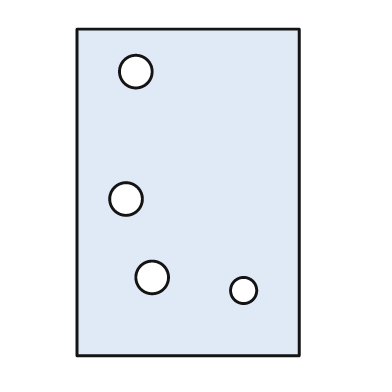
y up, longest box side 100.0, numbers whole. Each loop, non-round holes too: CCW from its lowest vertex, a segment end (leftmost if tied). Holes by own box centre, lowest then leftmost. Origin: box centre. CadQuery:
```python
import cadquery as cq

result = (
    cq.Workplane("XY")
    .moveTo(-34.0, -50.0)
    .lineTo(34.0, -50.0)
    .lineTo(34.0, 50.0)
    .lineTo(-34.0, 50.0)
    .close()
    .moveTo(17.0, -30.0)
    .circle(4.0)
    .moveTo(-11.0, -26.0)
    .circle(5.0)
    .moveTo(-19.0, -2.0)
    .circle(5.0)
    .moveTo(-16.0, 37.0)
    .circle(5.0)
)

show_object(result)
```